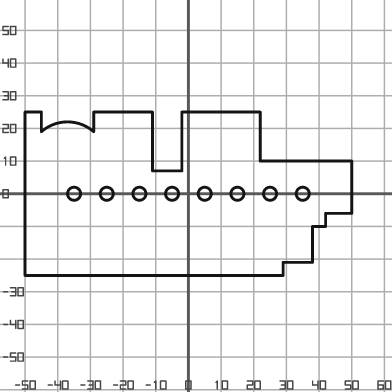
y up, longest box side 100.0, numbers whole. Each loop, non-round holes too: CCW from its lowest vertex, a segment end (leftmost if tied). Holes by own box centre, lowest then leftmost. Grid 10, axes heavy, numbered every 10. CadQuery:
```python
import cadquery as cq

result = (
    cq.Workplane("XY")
    .moveTo(-50.0, -25.0)
    .lineTo(29.0, -25.0)
    .lineTo(29.0, -21.0)
    .lineTo(38.0, -21.0)
    .lineTo(38.0, -10.0)
    .lineTo(42.0, -10.0)
    .lineTo(42.0, -6.0)
    .lineTo(50.0, -6.0)
    .lineTo(50.0, 10.0)
    .lineTo(22.0, 10.0)
    .lineTo(22.0, 25.0)
    .lineTo(-2.0, 25.0)
    .lineTo(-2.0, 7.0)
    .lineTo(-11.0, 7.0)
    .lineTo(-11.0, 25.0)
    .lineTo(-29.0, 25.0)
    .lineTo(-29.0, 19.0)
    .threePointArc((-37.0, 22.0), (-45.0, 19.0))
    .lineTo(-45.0, 25.0)
    .lineTo(-50.0, 25.0)
    .close()
    .moveTo(-35.0, 0.0)
    .circle(2.0)
    .moveTo(-25.0, 0.0)
    .circle(2.0)
    .moveTo(-15.0, 0.0)
    .circle(2.0)
    .moveTo(-5.0, 0.0)
    .circle(2.0)
    .moveTo(5.0, 0.0)
    .circle(2.0)
    .moveTo(15.0, 0.0)
    .circle(2.0)
    .moveTo(25.0, 0.0)
    .circle(2.0)
    .moveTo(35.0, 0.0)
    .circle(2.0)
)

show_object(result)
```